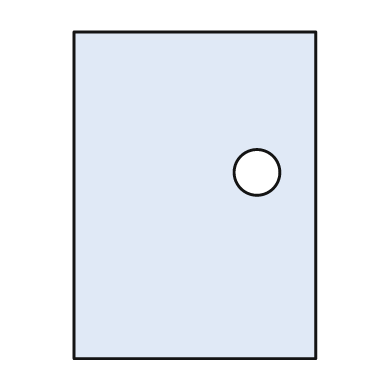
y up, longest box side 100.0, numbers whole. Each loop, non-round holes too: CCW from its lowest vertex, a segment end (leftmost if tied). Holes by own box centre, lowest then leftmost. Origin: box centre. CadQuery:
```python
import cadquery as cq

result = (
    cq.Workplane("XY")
    .moveTo(-37.0, -50.0)
    .lineTo(37.0, -50.0)
    .lineTo(37.0, 50.0)
    .lineTo(-37.0, 50.0)
    .close()
    .moveTo(19.0, 7.0)
    .circle(7.0)
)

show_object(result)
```